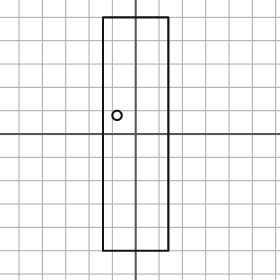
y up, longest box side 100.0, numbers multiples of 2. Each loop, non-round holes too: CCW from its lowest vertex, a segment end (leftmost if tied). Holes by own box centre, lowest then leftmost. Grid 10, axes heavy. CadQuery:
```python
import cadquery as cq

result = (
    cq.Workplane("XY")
    .moveTo(-14.0, -50.0)
    .lineTo(14.0, -50.0)
    .lineTo(14.0, 50.0)
    .lineTo(-14.0, 50.0)
    .close()
    .moveTo(-8.0, 8.0)
    .circle(2.0)
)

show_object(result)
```